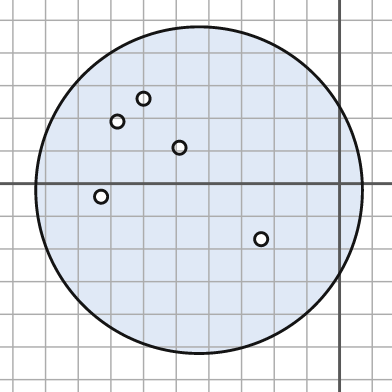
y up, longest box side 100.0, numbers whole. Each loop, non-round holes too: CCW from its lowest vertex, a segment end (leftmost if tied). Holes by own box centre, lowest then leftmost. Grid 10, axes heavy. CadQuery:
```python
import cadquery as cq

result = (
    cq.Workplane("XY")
    .moveTo(-43.0, -2.0)
    .circle(50.0)
    .moveTo(-24.0, -17.0)
    .circle(2.0)
    .moveTo(-73.0, -4.0)
    .circle(2.0)
    .moveTo(-49.0, 11.0)
    .circle(2.0)
    .moveTo(-68.0, 19.0)
    .circle(2.0)
    .moveTo(-60.0, 26.0)
    .circle(2.0)
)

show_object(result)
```